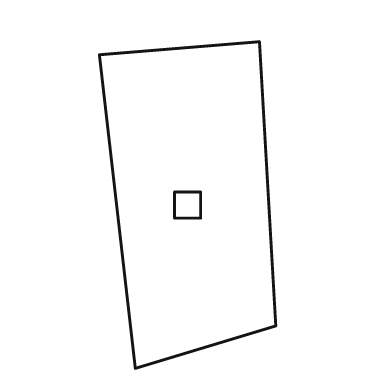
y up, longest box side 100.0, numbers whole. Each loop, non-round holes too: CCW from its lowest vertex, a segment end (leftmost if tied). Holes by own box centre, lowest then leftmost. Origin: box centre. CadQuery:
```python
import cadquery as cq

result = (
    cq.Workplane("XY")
    .moveTo(-16.0, -50.0)
    .lineTo(27.0, -37.0)
    .lineTo(22.0, 50.0)
    .lineTo(-27.0, 46.0)
    .close()
    .moveTo(-4.0, -4.0)
    .lineTo(4.0, -4.0)
    .lineTo(4.0, 4.0)
    .lineTo(-4.0, 4.0)
    .close()
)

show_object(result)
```